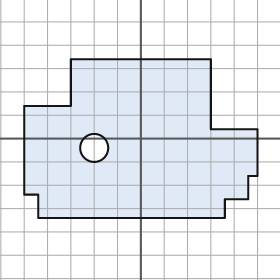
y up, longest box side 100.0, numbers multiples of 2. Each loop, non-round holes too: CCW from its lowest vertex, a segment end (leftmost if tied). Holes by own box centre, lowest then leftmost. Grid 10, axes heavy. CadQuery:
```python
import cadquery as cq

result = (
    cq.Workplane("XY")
    .moveTo(-44.0, -34.0)
    .lineTo(36.0, -34.0)
    .lineTo(36.0, -26.0)
    .lineTo(46.0, -26.0)
    .lineTo(46.0, -16.0)
    .lineTo(50.0, -16.0)
    .lineTo(50.0, 4.0)
    .lineTo(30.0, 4.0)
    .lineTo(30.0, 34.0)
    .lineTo(-30.0, 34.0)
    .lineTo(-30.0, 14.0)
    .lineTo(-50.0, 14.0)
    .lineTo(-50.0, -24.0)
    .lineTo(-44.0, -24.0)
    .close()
    .moveTo(-20.0, -4.0)
    .circle(6.0)
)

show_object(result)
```